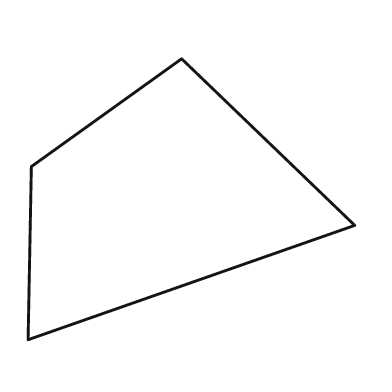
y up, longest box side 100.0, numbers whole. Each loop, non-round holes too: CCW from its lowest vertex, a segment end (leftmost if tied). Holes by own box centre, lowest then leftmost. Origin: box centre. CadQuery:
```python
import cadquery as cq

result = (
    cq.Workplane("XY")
    .moveTo(-50.0, -43.0)
    .lineTo(50.0, -8.0)
    .lineTo(-3.0, 43.0)
    .lineTo(-49.0, 10.0)
    .close()
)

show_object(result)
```